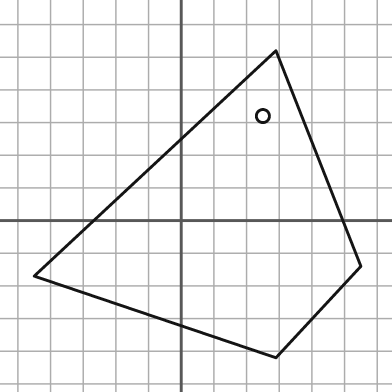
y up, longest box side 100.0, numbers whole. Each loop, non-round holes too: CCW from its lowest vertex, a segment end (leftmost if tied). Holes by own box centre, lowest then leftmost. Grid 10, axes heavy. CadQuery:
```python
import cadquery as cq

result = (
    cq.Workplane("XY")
    .moveTo(29.0, -42.0)
    .lineTo(55.0, -14.0)
    .lineTo(29.0, 52.0)
    .lineTo(-45.0, -17.0)
    .close()
    .moveTo(25.0, 32.0)
    .circle(2.0)
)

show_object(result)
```